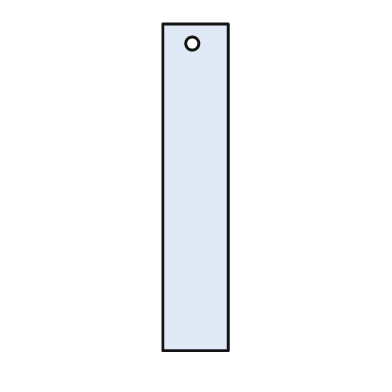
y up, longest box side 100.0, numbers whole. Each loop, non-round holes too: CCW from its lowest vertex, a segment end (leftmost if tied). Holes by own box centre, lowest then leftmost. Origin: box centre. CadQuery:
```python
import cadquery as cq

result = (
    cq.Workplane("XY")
    .moveTo(-10.0, -50.0)
    .lineTo(10.0, -50.0)
    .lineTo(10.0, 50.0)
    .lineTo(-10.0, 50.0)
    .close()
    .moveTo(-1.0, 44.0)
    .circle(2.0)
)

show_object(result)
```